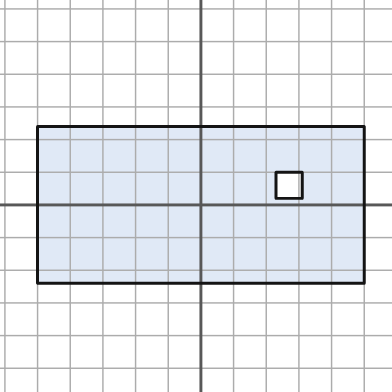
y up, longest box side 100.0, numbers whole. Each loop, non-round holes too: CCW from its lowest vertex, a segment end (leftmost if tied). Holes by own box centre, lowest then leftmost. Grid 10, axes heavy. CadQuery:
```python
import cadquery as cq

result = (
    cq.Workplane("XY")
    .moveTo(-50.0, -24.0)
    .lineTo(50.0, -24.0)
    .lineTo(50.0, 24.0)
    .lineTo(-50.0, 24.0)
    .close()
    .moveTo(23.0, 2.0)
    .lineTo(31.0, 2.0)
    .lineTo(31.0, 10.0)
    .lineTo(23.0, 10.0)
    .close()
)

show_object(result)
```